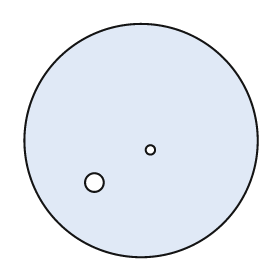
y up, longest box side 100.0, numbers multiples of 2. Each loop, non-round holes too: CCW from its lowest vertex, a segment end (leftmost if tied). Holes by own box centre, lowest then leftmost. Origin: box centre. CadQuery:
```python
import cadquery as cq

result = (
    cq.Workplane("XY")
    .moveTo(0.0, 0.0)
    .circle(50.0)
    .moveTo(-20.0, -18.0)
    .circle(4.0)
    .moveTo(4.0, -4.0)
    .circle(2.0)
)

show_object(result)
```